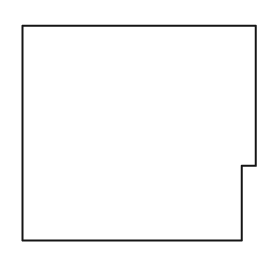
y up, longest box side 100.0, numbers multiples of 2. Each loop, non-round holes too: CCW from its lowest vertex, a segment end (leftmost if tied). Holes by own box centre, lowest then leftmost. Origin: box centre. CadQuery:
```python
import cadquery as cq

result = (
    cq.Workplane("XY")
    .moveTo(-50.0, -46.0)
    .lineTo(44.0, -46.0)
    .lineTo(44.0, -14.0)
    .lineTo(50.0, -14.0)
    .lineTo(50.0, 46.0)
    .lineTo(-50.0, 46.0)
    .close()
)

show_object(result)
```